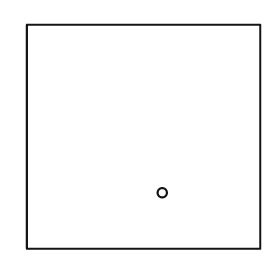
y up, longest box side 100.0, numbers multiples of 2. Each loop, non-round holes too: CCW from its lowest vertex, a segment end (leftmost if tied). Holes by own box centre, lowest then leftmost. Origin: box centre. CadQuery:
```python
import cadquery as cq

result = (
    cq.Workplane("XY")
    .moveTo(-50.0, -48.0)
    .lineTo(50.0, -48.0)
    .lineTo(50.0, 48.0)
    .lineTo(-50.0, 48.0)
    .close()
    .moveTo(8.0, -24.0)
    .circle(2.0)
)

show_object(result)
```